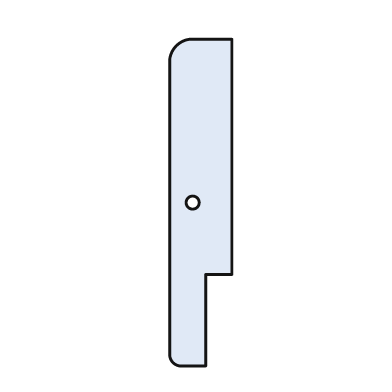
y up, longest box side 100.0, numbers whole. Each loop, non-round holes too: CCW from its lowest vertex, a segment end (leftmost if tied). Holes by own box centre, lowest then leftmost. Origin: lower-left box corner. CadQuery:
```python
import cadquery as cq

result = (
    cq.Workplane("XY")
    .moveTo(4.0, 0.0)
    .lineTo(11.0, 0.0)
    .lineTo(11.0, 28.0)
    .lineTo(19.0, 28.0)
    .lineTo(19.0, 100.0)
    .lineTo(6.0, 100.0)
    .threePointArc((2.0, 98.0), (0.0, 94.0))
    .lineTo(0.0, 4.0)
    .threePointArc((1.0, 1.0), (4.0, 0.0))
    .close()
    .moveTo(7.0, 50.0)
    .circle(2.0)
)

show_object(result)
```